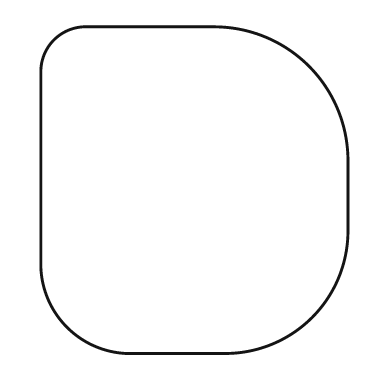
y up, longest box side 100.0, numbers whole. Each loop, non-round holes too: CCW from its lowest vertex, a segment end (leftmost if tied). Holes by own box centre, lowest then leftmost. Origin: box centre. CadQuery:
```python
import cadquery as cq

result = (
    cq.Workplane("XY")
    .moveTo(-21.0, -50.0)
    .lineTo(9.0, -50.0)
    .threePointArc((36.0, -39.0), (47.0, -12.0))
    .lineTo(47.0, 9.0)
    .threePointArc((35.0, 38.0), (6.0, 50.0))
    .lineTo(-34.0, 50.0)
    .threePointArc((-43.0, 46.0), (-47.0, 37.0))
    .lineTo(-47.0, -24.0)
    .threePointArc((-39.0, -42.0), (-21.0, -50.0))
    .close()
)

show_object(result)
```